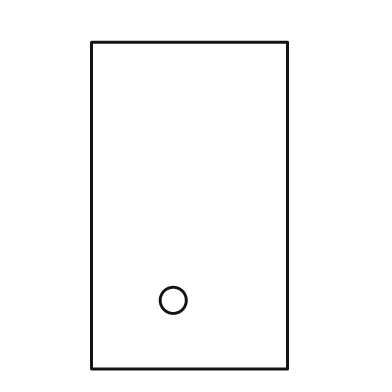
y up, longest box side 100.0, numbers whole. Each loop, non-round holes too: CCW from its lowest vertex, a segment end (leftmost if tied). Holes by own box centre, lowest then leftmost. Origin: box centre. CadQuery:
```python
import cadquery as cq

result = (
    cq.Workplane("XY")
    .moveTo(-30.0, -50.0)
    .lineTo(30.0, -50.0)
    .lineTo(30.0, 50.0)
    .lineTo(-30.0, 50.0)
    .close()
    .moveTo(-5.0, -29.0)
    .circle(4.0)
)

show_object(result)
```